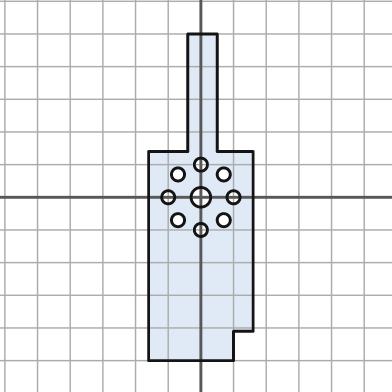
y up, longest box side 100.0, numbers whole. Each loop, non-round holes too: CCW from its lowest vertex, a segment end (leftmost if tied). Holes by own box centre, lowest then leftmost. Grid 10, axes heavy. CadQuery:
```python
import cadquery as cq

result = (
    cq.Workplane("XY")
    .moveTo(-16.0, -50.0)
    .lineTo(10.0, -50.0)
    .lineTo(10.0, -41.0)
    .lineTo(16.0, -41.0)
    .lineTo(16.0, 14.0)
    .lineTo(5.0, 14.0)
    .lineTo(5.0, 50.0)
    .lineTo(-4.0, 50.0)
    .lineTo(-4.0, 14.0)
    .lineTo(-16.0, 14.0)
    .close()
    .moveTo(0.0, -10.0)
    .circle(2.0)
    .moveTo(-7.0, -7.0)
    .circle(2.0)
    .moveTo(7.0, -7.0)
    .circle(2.0)
    .moveTo(-10.0, 0.0)
    .circle(2.0)
    .moveTo(0.0, 0.0)
    .circle(3.0)
    .moveTo(10.0, 0.0)
    .circle(2.0)
    .moveTo(-7.0, 7.0)
    .circle(2.0)
    .moveTo(7.0, 7.0)
    .circle(2.0)
    .moveTo(0.0, 10.0)
    .circle(2.0)
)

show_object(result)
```